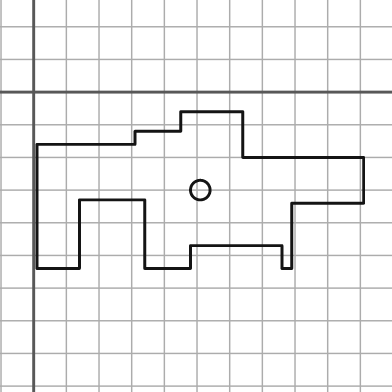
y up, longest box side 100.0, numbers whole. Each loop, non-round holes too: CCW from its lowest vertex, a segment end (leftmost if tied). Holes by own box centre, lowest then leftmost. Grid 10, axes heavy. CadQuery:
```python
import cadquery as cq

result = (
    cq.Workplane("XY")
    .moveTo(1.0, -54.0)
    .lineTo(14.0, -54.0)
    .lineTo(14.0, -33.0)
    .lineTo(34.0, -33.0)
    .lineTo(34.0, -54.0)
    .lineTo(48.0, -54.0)
    .lineTo(48.0, -47.0)
    .lineTo(76.0, -47.0)
    .lineTo(76.0, -54.0)
    .lineTo(79.0, -54.0)
    .lineTo(79.0, -34.0)
    .lineTo(101.0, -34.0)
    .lineTo(101.0, -20.0)
    .lineTo(64.0, -20.0)
    .lineTo(64.0, -6.0)
    .lineTo(45.0, -6.0)
    .lineTo(45.0, -12.0)
    .lineTo(31.0, -12.0)
    .lineTo(31.0, -16.0)
    .lineTo(1.0, -16.0)
    .close()
    .moveTo(51.0, -30.0)
    .circle(3.0)
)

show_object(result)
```